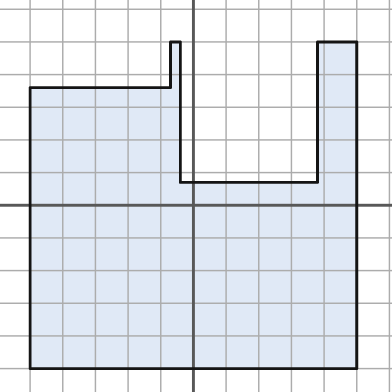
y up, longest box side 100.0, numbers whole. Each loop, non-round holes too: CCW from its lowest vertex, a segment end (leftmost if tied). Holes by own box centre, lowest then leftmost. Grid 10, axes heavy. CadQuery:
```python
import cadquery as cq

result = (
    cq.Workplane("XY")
    .moveTo(-50.0, -50.0)
    .lineTo(50.0, -50.0)
    .lineTo(50.0, 50.0)
    .lineTo(38.0, 50.0)
    .lineTo(38.0, 7.0)
    .lineTo(-4.0, 7.0)
    .lineTo(-4.0, 50.0)
    .lineTo(-7.0, 50.0)
    .lineTo(-7.0, 36.0)
    .lineTo(-50.0, 36.0)
    .close()
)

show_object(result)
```